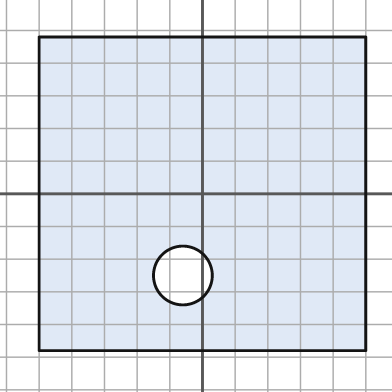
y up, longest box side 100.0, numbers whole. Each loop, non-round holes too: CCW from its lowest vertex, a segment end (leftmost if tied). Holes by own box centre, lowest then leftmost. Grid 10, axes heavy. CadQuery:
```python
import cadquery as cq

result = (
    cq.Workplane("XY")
    .moveTo(-50.0, -48.0)
    .lineTo(50.0, -48.0)
    .lineTo(50.0, 48.0)
    .lineTo(-50.0, 48.0)
    .close()
    .moveTo(-6.0, -25.0)
    .circle(9.0)
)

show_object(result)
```